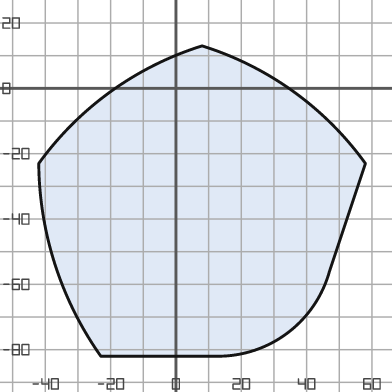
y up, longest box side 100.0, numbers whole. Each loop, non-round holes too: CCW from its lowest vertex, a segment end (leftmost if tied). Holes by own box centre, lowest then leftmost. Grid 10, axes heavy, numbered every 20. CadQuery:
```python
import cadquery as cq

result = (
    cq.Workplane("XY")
    .moveTo(-23.0, -82.0)
    .lineTo(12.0, -82.0)
    .threePointArc((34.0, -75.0), (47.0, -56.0))
    .lineTo(58.0, -23.0)
    .threePointArc((36.0, -1.0), (8.0, 13.0))
    .threePointArc((-20.0, -1.0), (-42.0, -23.0))
    .threePointArc((-37.0, -54.0), (-23.0, -82.0))
    .close()
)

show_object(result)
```